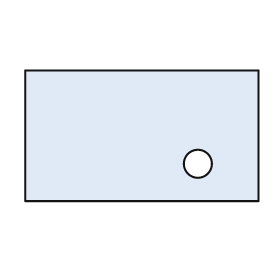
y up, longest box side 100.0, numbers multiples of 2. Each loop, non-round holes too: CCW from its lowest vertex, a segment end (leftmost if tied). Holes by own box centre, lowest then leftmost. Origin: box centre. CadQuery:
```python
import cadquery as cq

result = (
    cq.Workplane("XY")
    .moveTo(-50.0, -28.0)
    .lineTo(50.0, -28.0)
    .lineTo(50.0, 28.0)
    .lineTo(-50.0, 28.0)
    .close()
    .moveTo(24.0, -12.0)
    .circle(6.0)
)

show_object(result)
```